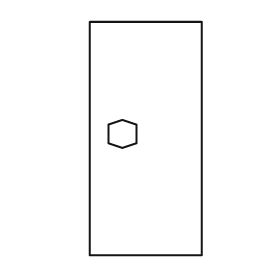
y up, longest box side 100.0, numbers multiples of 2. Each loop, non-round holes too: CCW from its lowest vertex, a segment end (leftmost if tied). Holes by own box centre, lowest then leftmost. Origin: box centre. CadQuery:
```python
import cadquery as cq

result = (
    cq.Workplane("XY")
    .moveTo(-24.0, -50.0)
    .lineTo(24.0, -50.0)
    .lineTo(24.0, 50.0)
    .lineTo(-24.0, 50.0)
    .close()
    .moveTo(-10.0, -4.0)
    .lineTo(-4.0, -2.0)
    .lineTo(-4.0, 6.0)
    .lineTo(-10.0, 8.0)
    .lineTo(-16.0, 6.0)
    .lineTo(-16.0, -2.0)
    .close()
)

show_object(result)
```